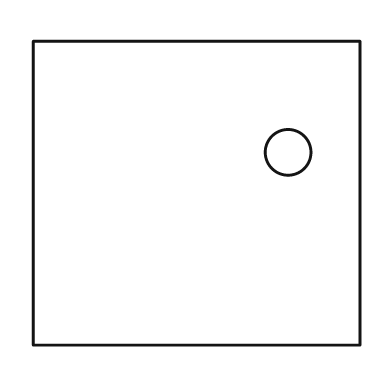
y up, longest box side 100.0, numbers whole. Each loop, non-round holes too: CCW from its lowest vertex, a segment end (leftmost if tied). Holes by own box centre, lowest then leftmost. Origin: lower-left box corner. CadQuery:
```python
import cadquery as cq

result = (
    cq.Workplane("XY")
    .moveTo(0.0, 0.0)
    .lineTo(100.0, 0.0)
    .lineTo(100.0, 93.0)
    .lineTo(0.0, 93.0)
    .close()
    .moveTo(78.0, 59.0)
    .circle(7.0)
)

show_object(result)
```